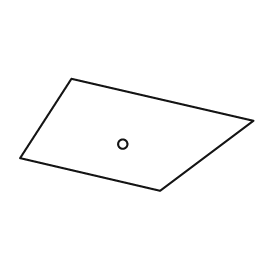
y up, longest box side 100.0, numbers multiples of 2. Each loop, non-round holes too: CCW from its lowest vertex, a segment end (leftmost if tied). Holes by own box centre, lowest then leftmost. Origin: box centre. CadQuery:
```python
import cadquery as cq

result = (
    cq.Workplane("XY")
    .moveTo(10.0, -24.0)
    .lineTo(50.0, 6.0)
    .lineTo(-28.0, 24.0)
    .lineTo(-50.0, -10.0)
    .close()
    .moveTo(-6.0, -4.0)
    .circle(2.0)
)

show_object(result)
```